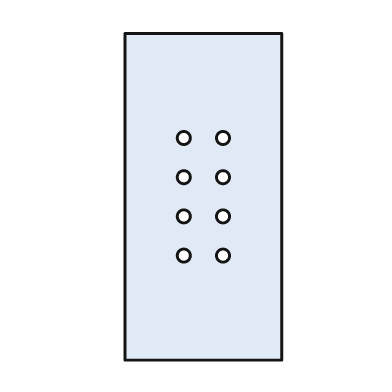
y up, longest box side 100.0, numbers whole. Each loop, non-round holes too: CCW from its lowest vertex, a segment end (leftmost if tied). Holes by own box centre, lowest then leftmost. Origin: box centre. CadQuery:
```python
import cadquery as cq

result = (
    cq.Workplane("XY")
    .moveTo(-24.0, -50.0)
    .lineTo(24.0, -50.0)
    .lineTo(24.0, 50.0)
    .lineTo(-24.0, 50.0)
    .close()
    .moveTo(-6.0, -18.0)
    .circle(2.0)
    .moveTo(6.0, -18.0)
    .circle(2.0)
    .moveTo(-6.0, -6.0)
    .circle(2.0)
    .moveTo(6.0, -6.0)
    .circle(2.0)
    .moveTo(-6.0, 6.0)
    .circle(2.0)
    .moveTo(6.0, 6.0)
    .circle(2.0)
    .moveTo(-6.0, 18.0)
    .circle(2.0)
    .moveTo(6.0, 18.0)
    .circle(2.0)
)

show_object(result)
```